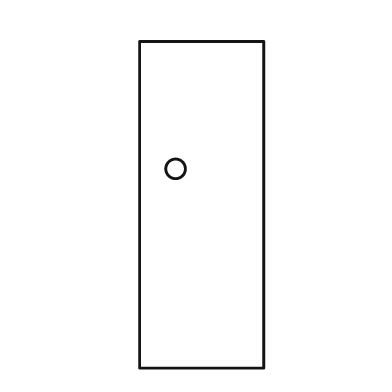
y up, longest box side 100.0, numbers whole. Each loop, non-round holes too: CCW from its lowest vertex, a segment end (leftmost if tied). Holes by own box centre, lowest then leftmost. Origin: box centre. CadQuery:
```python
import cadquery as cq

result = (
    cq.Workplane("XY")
    .moveTo(-19.0, -50.0)
    .lineTo(19.0, -50.0)
    .lineTo(19.0, 50.0)
    .lineTo(-19.0, 50.0)
    .close()
    .moveTo(-8.0, 11.0)
    .circle(3.0)
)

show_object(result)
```